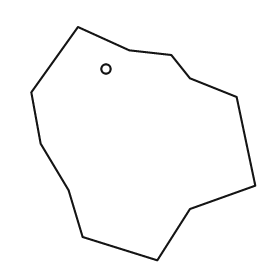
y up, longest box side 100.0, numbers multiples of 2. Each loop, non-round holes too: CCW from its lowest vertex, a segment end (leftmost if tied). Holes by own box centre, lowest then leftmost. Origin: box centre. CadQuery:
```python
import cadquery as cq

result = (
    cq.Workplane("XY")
    .moveTo(6.0, -50.0)
    .lineTo(20.0, -28.0)
    .lineTo(48.0, -18.0)
    .lineTo(40.0, 20.0)
    .lineTo(20.0, 28.0)
    .lineTo(12.0, 38.0)
    .lineTo(-6.0, 40.0)
    .lineTo(-28.0, 50.0)
    .lineTo(-48.0, 22.0)
    .lineTo(-44.0, 0.0)
    .lineTo(-32.0, -20.0)
    .lineTo(-26.0, -40.0)
    .close()
    .moveTo(-16.0, 32.0)
    .circle(2.0)
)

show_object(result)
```